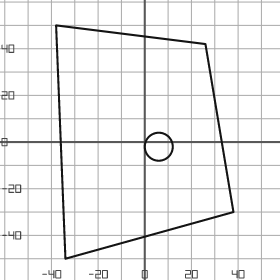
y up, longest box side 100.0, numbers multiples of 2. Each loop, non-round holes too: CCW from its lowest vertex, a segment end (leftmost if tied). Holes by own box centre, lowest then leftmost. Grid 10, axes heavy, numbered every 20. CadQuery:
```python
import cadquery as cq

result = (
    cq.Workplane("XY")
    .moveTo(-34.0, -50.0)
    .lineTo(38.0, -30.0)
    .lineTo(26.0, 42.0)
    .lineTo(-38.0, 50.0)
    .close()
    .moveTo(6.0, -2.0)
    .circle(6.0)
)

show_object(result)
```